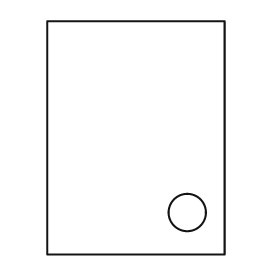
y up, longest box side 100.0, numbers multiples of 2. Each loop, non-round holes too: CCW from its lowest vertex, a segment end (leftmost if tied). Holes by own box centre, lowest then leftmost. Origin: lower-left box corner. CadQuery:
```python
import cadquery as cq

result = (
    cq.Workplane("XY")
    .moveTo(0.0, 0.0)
    .lineTo(76.0, 0.0)
    .lineTo(76.0, 100.0)
    .lineTo(0.0, 100.0)
    .close()
    .moveTo(60.0, 18.0)
    .circle(8.0)
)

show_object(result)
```